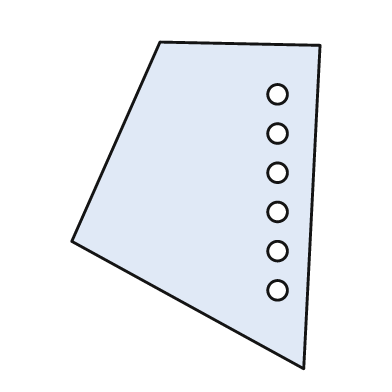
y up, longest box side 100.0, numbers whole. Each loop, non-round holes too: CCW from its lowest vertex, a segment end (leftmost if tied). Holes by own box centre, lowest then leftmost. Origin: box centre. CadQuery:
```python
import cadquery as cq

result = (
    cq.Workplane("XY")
    .moveTo(33.0, -50.0)
    .lineTo(38.0, 49.0)
    .lineTo(-11.0, 50.0)
    .lineTo(-38.0, -11.0)
    .close()
    .moveTo(25.0, -26.0)
    .circle(3.0)
    .moveTo(25.0, -14.0)
    .circle(3.0)
    .moveTo(25.0, -2.0)
    .circle(3.0)
    .moveTo(25.0, 10.0)
    .circle(3.0)
    .moveTo(25.0, 22.0)
    .circle(3.0)
    .moveTo(25.0, 34.0)
    .circle(3.0)
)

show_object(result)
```